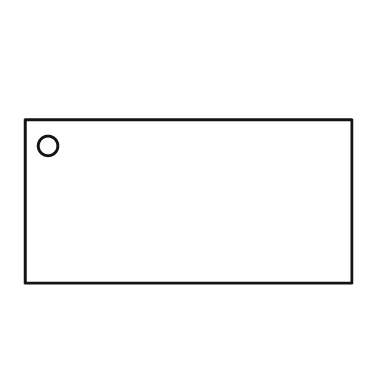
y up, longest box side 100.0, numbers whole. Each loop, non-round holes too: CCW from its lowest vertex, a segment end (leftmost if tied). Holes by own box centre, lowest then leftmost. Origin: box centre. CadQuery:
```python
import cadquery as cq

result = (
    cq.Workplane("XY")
    .moveTo(-50.0, -25.0)
    .lineTo(50.0, -25.0)
    .lineTo(50.0, 25.0)
    .lineTo(-50.0, 25.0)
    .close()
    .moveTo(-43.0, 17.0)
    .circle(3.0)
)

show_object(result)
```